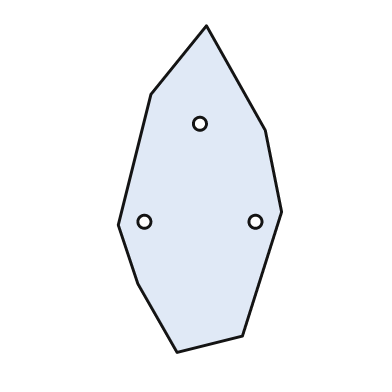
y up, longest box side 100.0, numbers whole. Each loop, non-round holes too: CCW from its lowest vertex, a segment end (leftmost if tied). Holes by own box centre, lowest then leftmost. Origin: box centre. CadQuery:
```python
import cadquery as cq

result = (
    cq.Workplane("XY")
    .moveTo(-7.0, -50.0)
    .lineTo(13.0, -45.0)
    .lineTo(25.0, -7.0)
    .lineTo(20.0, 18.0)
    .lineTo(2.0, 50.0)
    .lineTo(-15.0, 29.0)
    .lineTo(-25.0, -11.0)
    .lineTo(-19.0, -29.0)
    .close()
    .moveTo(-17.0, -10.0)
    .circle(2.0)
    .moveTo(17.0, -10.0)
    .circle(2.0)
    .moveTo(0.0, 20.0)
    .circle(2.0)
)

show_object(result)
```